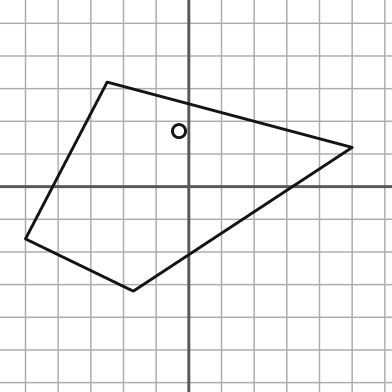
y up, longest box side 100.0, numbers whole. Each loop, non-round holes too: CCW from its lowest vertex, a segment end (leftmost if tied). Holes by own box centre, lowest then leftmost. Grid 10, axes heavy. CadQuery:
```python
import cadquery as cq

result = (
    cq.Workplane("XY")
    .moveTo(-17.0, -32.0)
    .lineTo(50.0, 12.0)
    .lineTo(-25.0, 32.0)
    .lineTo(-50.0, -16.0)
    .close()
    .moveTo(-3.0, 17.0)
    .circle(2.0)
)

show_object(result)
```